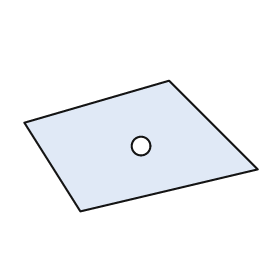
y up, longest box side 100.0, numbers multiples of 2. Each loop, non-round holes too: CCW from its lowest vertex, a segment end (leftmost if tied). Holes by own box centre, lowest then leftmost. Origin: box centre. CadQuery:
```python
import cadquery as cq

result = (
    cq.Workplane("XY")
    .moveTo(-26.0, -28.0)
    .lineTo(50.0, -10.0)
    .lineTo(12.0, 28.0)
    .lineTo(-50.0, 10.0)
    .close()
    .moveTo(0.0, 0.0)
    .circle(4.0)
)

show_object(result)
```